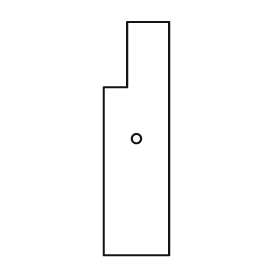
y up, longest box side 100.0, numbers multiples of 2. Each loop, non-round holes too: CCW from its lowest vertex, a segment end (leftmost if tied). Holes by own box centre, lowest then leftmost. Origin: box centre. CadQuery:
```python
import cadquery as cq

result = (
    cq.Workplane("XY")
    .moveTo(-14.0, -50.0)
    .lineTo(14.0, -50.0)
    .lineTo(14.0, 50.0)
    .lineTo(-4.0, 50.0)
    .lineTo(-4.0, 22.0)
    .lineTo(-14.0, 22.0)
    .close()
    .moveTo(0.0, 0.0)
    .circle(2.0)
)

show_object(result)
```